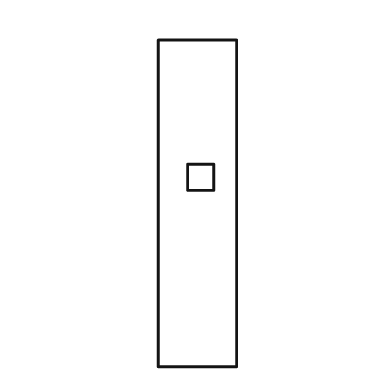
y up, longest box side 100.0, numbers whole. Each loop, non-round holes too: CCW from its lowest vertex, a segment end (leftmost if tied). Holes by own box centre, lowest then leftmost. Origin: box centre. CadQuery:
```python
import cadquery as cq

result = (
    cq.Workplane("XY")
    .moveTo(-12.0, -50.0)
    .lineTo(12.0, -50.0)
    .lineTo(12.0, 50.0)
    .lineTo(-12.0, 50.0)
    .close()
    .moveTo(-3.0, 4.0)
    .lineTo(5.0, 4.0)
    .lineTo(5.0, 12.0)
    .lineTo(-3.0, 12.0)
    .close()
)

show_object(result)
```